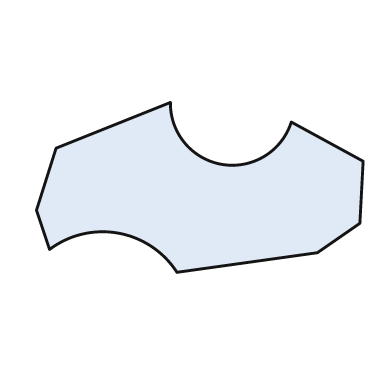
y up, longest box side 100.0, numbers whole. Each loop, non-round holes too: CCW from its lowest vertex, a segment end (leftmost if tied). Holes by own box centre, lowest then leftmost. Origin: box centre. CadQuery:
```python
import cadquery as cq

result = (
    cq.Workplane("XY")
    .moveTo(-7.0, -26.0)
    .lineTo(36.0, -20.0)
    .lineTo(49.0, -11.0)
    .lineTo(50.0, 8.0)
    .lineTo(28.0, 20.0)
    .threePointArc((7.0, 7.0), (-9.0, 26.0))
    .lineTo(-44.0, 12.0)
    .lineTo(-50.0, -7.0)
    .lineTo(-46.0, -19.0)
    .threePointArc((-25.0, -14.0), (-7.0, -26.0))
    .close()
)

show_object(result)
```